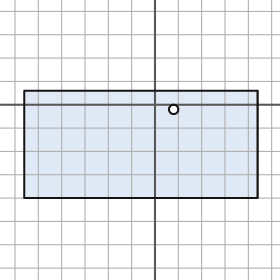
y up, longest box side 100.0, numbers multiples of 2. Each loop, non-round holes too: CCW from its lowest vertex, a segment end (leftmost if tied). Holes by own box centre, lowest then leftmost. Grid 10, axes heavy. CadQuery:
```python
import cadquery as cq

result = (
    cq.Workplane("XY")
    .moveTo(-56.0, -40.0)
    .lineTo(44.0, -40.0)
    .lineTo(44.0, 6.0)
    .lineTo(-56.0, 6.0)
    .close()
    .moveTo(8.0, -2.0)
    .circle(2.0)
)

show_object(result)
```